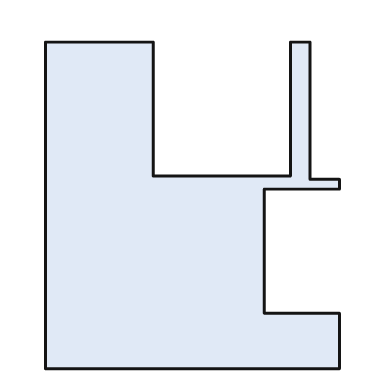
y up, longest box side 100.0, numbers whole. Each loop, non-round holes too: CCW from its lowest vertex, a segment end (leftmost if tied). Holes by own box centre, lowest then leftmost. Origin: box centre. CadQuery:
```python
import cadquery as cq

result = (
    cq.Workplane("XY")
    .moveTo(-45.0, -50.0)
    .lineTo(45.0, -50.0)
    .lineTo(45.0, -33.0)
    .lineTo(22.0, -33.0)
    .lineTo(22.0, 5.0)
    .lineTo(45.0, 5.0)
    .lineTo(45.0, 8.0)
    .lineTo(36.0, 8.0)
    .lineTo(36.0, 50.0)
    .lineTo(30.0, 50.0)
    .lineTo(30.0, 9.0)
    .lineTo(-12.0, 9.0)
    .lineTo(-12.0, 50.0)
    .lineTo(-45.0, 50.0)
    .close()
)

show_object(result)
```